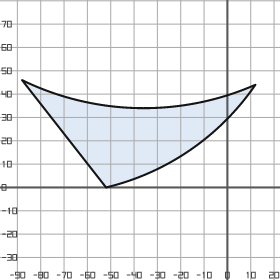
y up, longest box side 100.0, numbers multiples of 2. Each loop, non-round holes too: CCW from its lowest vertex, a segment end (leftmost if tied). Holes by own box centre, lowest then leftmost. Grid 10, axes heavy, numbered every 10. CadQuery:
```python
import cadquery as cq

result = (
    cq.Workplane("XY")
    .moveTo(-52.0, 0.0)
    .threePointArc((-16.0, 16.0), (12.0, 44.0))
    .threePointArc((-38.0, 34.0), (-88.0, 46.0))
    .close()
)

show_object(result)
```